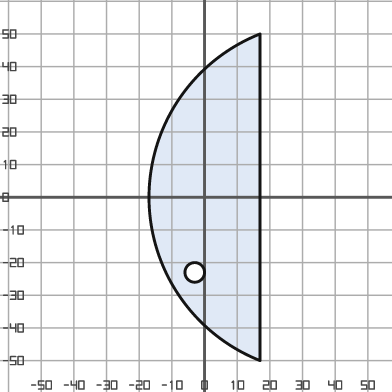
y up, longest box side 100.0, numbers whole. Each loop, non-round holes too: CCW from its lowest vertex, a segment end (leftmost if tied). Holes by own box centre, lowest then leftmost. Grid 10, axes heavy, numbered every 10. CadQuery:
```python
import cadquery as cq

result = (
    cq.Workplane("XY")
    .moveTo(17.0, -50.0)
    .lineTo(17.0, 50.0)
    .threePointArc((-17.0, 0.0), (17.0, -50.0))
    .close()
    .moveTo(-3.0, -23.0)
    .circle(3.0)
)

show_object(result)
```